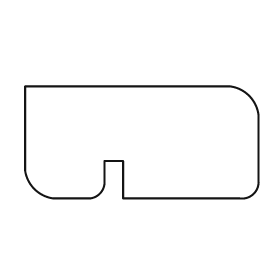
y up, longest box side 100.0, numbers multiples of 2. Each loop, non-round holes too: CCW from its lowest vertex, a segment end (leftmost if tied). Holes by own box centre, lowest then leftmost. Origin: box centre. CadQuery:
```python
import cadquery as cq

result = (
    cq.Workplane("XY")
    .moveTo(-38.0, -24.0)
    .lineTo(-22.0, -24.0)
    .threePointArc((-18.0, -22.0), (-16.0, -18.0))
    .lineTo(-16.0, -8.0)
    .lineTo(-8.0, -8.0)
    .lineTo(-8.0, -24.0)
    .lineTo(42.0, -24.0)
    .threePointArc((48.0, -22.0), (50.0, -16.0))
    .lineTo(50.0, 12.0)
    .threePointArc((46.0, 20.0), (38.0, 24.0))
    .lineTo(-50.0, 24.0)
    .lineTo(-50.0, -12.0)
    .threePointArc((-46.0, -20.0), (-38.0, -24.0))
    .close()
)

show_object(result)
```